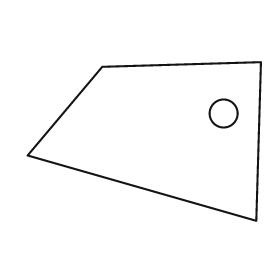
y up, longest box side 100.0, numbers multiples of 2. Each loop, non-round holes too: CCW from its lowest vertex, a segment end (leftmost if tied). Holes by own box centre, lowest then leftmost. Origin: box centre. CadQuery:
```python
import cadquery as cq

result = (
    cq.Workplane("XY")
    .moveTo(48.0, -34.0)
    .lineTo(50.0, 34.0)
    .lineTo(-18.0, 32.0)
    .lineTo(-50.0, -6.0)
    .close()
    .moveTo(34.0, 12.0)
    .circle(6.0)
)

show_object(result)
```